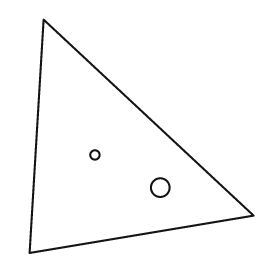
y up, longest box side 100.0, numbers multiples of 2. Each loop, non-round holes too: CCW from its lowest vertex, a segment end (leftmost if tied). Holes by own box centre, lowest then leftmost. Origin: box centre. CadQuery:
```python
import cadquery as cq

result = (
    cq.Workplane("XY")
    .moveTo(-48.0, -50.0)
    .lineTo(48.0, -34.0)
    .lineTo(-42.0, 50.0)
    .close()
    .moveTo(8.0, -22.0)
    .circle(4.0)
    .moveTo(-20.0, -8.0)
    .circle(2.0)
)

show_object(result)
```